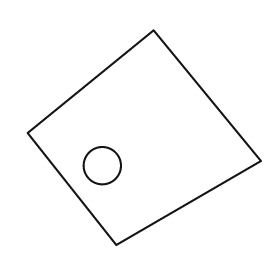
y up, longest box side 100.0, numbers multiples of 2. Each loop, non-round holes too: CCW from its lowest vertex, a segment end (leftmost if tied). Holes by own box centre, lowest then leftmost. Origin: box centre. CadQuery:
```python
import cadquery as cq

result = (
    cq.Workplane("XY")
    .moveTo(-12.0, -46.0)
    .lineTo(50.0, -10.0)
    .lineTo(4.0, 46.0)
    .lineTo(-50.0, 2.0)
    .close()
    .moveTo(-18.0, -12.0)
    .circle(8.0)
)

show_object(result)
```